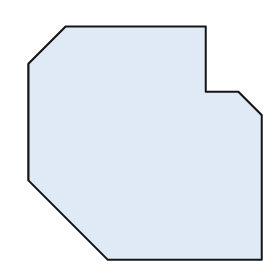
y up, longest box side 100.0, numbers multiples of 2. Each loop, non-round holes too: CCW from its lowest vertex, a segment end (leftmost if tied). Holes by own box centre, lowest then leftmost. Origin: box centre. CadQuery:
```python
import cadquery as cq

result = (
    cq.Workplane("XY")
    .moveTo(-16.0, -50.0)
    .lineTo(50.0, -50.0)
    .lineTo(50.0, 12.0)
    .lineTo(40.0, 22.0)
    .lineTo(26.0, 22.0)
    .lineTo(26.0, 50.0)
    .lineTo(-34.0, 50.0)
    .lineTo(-50.0, 34.0)
    .lineTo(-50.0, -16.0)
    .close()
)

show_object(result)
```